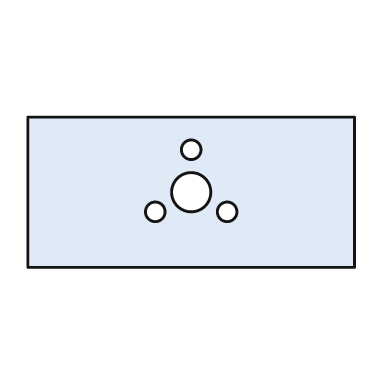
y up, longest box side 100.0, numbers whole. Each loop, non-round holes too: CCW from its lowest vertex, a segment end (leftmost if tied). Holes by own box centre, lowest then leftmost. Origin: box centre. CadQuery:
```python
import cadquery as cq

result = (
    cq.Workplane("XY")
    .moveTo(-50.0, -23.0)
    .lineTo(50.0, -23.0)
    .lineTo(50.0, 23.0)
    .lineTo(-50.0, 23.0)
    .close()
    .moveTo(-11.0, -6.0)
    .circle(3.0)
    .moveTo(11.0, -6.0)
    .circle(3.0)
    .moveTo(0.0, 0.0)
    .circle(6.0)
    .moveTo(0.0, 13.0)
    .circle(3.0)
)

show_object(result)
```